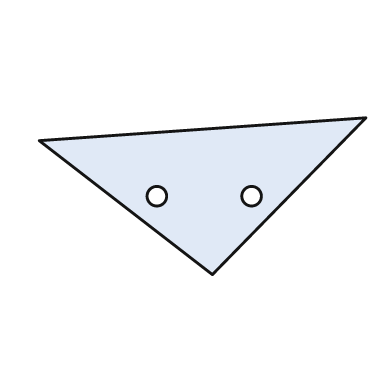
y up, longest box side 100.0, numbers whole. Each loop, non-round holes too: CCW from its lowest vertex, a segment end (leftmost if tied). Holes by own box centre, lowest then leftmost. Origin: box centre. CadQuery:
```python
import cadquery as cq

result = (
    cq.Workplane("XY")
    .moveTo(3.0, -24.0)
    .lineTo(50.0, 24.0)
    .lineTo(-50.0, 17.0)
    .close()
    .moveTo(-14.0, 0.0)
    .circle(3.0)
    .moveTo(15.0, 0.0)
    .circle(3.0)
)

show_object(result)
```